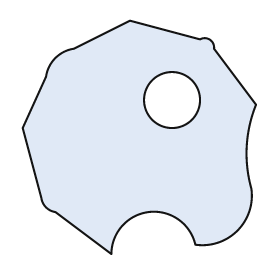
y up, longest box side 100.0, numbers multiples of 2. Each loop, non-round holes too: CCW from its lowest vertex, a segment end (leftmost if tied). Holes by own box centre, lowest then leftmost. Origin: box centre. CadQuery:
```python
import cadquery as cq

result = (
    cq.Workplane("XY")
    .moveTo(-12.0, -50.0)
    .threePointArc((4.0, -32.0), (24.0, -46.0))
    .threePointArc((42.0, -40.0), (48.0, -22.0))
    .threePointArc((46.0, -4.0), (50.0, 14.0))
    .lineTo(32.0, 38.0)
    .threePointArc((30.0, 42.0), (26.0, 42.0))
    .lineTo(-4.0, 50.0)
    .lineTo(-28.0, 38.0)
    .threePointArc((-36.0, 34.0), (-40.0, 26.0))
    .lineTo(-50.0, 4.0)
    .lineTo(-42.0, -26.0)
    .threePointArc((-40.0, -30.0), (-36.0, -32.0))
    .close()
    .moveTo(14.0, 16.0)
    .circle(12.0)
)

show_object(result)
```